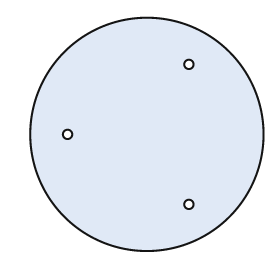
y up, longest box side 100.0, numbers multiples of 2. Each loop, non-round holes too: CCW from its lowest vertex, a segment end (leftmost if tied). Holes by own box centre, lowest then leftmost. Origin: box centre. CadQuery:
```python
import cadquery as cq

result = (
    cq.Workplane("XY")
    .moveTo(0.0, 0.0)
    .circle(50.0)
    .moveTo(18.0, -30.0)
    .circle(2.0)
    .moveTo(-34.0, 0.0)
    .circle(2.0)
    .moveTo(18.0, 30.0)
    .circle(2.0)
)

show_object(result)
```